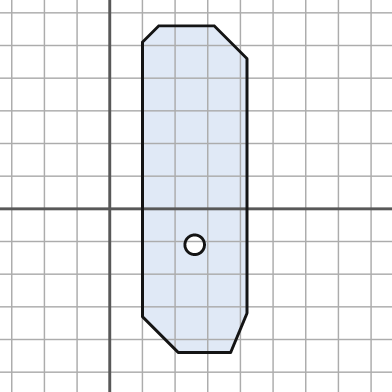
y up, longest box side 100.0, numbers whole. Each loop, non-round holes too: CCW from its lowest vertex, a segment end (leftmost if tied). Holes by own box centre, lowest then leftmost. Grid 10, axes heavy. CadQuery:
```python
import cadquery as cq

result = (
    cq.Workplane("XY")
    .moveTo(21.0, -44.0)
    .lineTo(37.0, -44.0)
    .lineTo(42.0, -32.0)
    .lineTo(42.0, 46.0)
    .lineTo(32.0, 56.0)
    .lineTo(15.0, 56.0)
    .lineTo(10.0, 51.0)
    .lineTo(10.0, -33.0)
    .close()
    .moveTo(26.0, -11.0)
    .circle(3.0)
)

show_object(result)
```